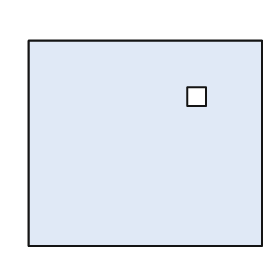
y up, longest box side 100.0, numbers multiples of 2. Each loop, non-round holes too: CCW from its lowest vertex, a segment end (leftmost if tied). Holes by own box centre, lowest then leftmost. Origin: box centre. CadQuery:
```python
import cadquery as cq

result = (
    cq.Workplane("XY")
    .moveTo(-50.0, -44.0)
    .lineTo(50.0, -44.0)
    .lineTo(50.0, 44.0)
    .lineTo(-50.0, 44.0)
    .close()
    .moveTo(18.0, 16.0)
    .lineTo(26.0, 16.0)
    .lineTo(26.0, 24.0)
    .lineTo(18.0, 24.0)
    .close()
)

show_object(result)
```